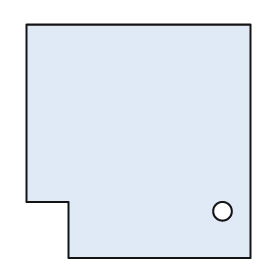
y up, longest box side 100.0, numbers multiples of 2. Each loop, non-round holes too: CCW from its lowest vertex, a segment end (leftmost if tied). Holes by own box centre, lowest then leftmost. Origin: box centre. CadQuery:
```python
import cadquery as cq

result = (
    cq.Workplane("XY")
    .moveTo(-30.0, -50.0)
    .lineTo(48.0, -50.0)
    .lineTo(48.0, 50.0)
    .lineTo(-48.0, 50.0)
    .lineTo(-48.0, -26.0)
    .lineTo(-30.0, -26.0)
    .close()
    .moveTo(36.0, -30.0)
    .circle(4.0)
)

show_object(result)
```